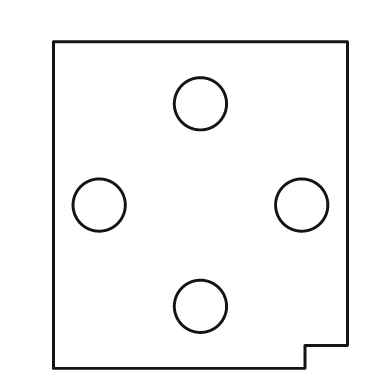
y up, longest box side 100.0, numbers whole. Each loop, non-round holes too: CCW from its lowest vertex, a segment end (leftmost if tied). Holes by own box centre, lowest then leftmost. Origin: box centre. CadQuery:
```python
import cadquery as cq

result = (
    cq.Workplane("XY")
    .moveTo(-45.0, -50.0)
    .lineTo(32.0, -50.0)
    .lineTo(32.0, -43.0)
    .lineTo(45.0, -43.0)
    .lineTo(45.0, 50.0)
    .lineTo(-45.0, 50.0)
    .close()
    .moveTo(0.0, -31.0)
    .circle(8.0)
    .moveTo(-31.0, 0.0)
    .circle(8.0)
    .moveTo(31.0, 0.0)
    .circle(8.0)
    .moveTo(0.0, 31.0)
    .circle(8.0)
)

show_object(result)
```